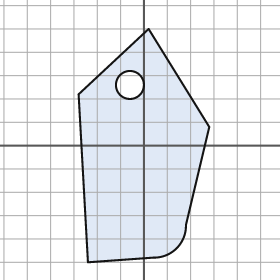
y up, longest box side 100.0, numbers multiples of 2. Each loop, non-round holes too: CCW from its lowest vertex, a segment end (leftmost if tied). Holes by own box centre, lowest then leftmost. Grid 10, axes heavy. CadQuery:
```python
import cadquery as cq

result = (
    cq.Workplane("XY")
    .moveTo(-24.0, -50.0)
    .lineTo(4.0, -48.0)
    .threePointArc((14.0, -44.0), (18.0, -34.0))
    .lineTo(28.0, 8.0)
    .lineTo(2.0, 50.0)
    .lineTo(-28.0, 22.0)
    .close()
    .moveTo(-6.0, 26.0)
    .circle(6.0)
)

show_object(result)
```